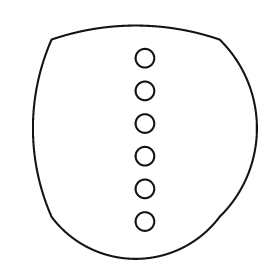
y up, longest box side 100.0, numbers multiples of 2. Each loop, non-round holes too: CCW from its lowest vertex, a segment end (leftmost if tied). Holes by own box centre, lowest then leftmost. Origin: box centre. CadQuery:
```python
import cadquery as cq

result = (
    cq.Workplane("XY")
    .moveTo(-40.0, -32.0)
    .threePointArc((-4.0, -50.0), (32.0, -32.0))
    .threePointArc((48.0, 6.0), (32.0, 44.0))
    .threePointArc((-4.0, 50.0), (-40.0, 44.0))
    .threePointArc((-48.0, 6.0), (-40.0, -32.0))
    .close()
    .moveTo(0.0, -34.0)
    .circle(4.0)
    .moveTo(0.0, -20.0)
    .circle(4.0)
    .moveTo(0.0, -6.0)
    .circle(4.0)
    .moveTo(0.0, 8.0)
    .circle(4.0)
    .moveTo(0.0, 22.0)
    .circle(4.0)
    .moveTo(0.0, 36.0)
    .circle(4.0)
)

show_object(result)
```